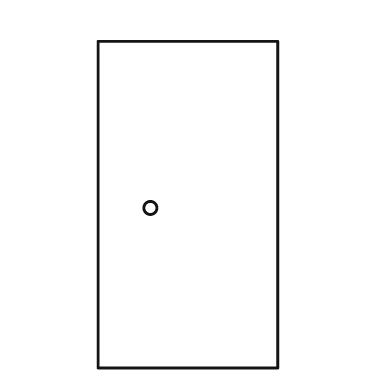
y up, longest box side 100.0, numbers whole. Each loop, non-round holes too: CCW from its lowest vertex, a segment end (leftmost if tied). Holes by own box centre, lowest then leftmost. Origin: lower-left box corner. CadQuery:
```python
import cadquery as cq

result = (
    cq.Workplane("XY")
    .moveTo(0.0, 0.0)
    .lineTo(55.0, 0.0)
    .lineTo(55.0, 100.0)
    .lineTo(0.0, 100.0)
    .close()
    .moveTo(16.0, 49.0)
    .circle(2.0)
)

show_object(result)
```